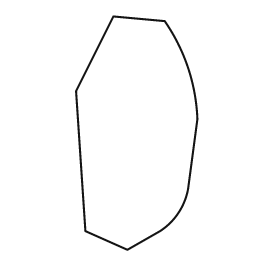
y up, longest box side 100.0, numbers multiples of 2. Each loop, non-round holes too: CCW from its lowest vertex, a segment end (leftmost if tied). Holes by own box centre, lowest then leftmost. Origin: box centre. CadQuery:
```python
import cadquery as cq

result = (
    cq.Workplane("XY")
    .moveTo(-4.0, -50.0)
    .lineTo(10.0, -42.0)
    .threePointArc((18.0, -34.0), (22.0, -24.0))
    .lineTo(26.0, 6.0)
    .threePointArc((22.0, 28.0), (12.0, 48.0))
    .lineTo(-10.0, 50.0)
    .lineTo(-26.0, 18.0)
    .lineTo(-22.0, -42.0)
    .close()
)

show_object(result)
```